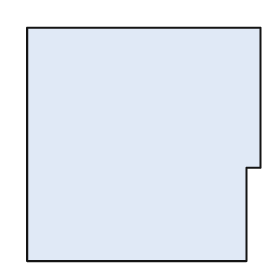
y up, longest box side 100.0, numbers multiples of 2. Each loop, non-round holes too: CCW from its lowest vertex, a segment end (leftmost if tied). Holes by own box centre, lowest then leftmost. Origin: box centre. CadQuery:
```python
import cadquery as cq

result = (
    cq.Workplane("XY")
    .moveTo(-50.0, -50.0)
    .lineTo(44.0, -50.0)
    .lineTo(44.0, -10.0)
    .lineTo(50.0, -10.0)
    .lineTo(50.0, 50.0)
    .lineTo(-50.0, 50.0)
    .close()
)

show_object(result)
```